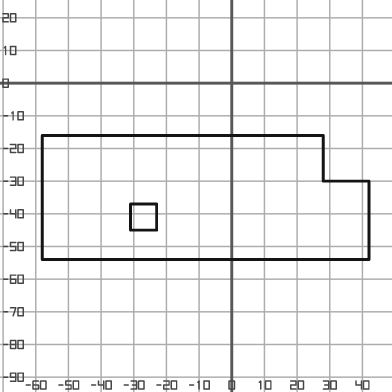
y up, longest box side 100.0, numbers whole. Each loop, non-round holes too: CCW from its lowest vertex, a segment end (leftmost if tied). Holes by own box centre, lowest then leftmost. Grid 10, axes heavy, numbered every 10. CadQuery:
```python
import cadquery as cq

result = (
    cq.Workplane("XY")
    .moveTo(-58.0, -54.0)
    .lineTo(42.0, -54.0)
    .lineTo(42.0, -30.0)
    .lineTo(28.0, -30.0)
    .lineTo(28.0, -16.0)
    .lineTo(-58.0, -16.0)
    .close()
    .moveTo(-31.0, -45.0)
    .lineTo(-23.0, -45.0)
    .lineTo(-23.0, -37.0)
    .lineTo(-31.0, -37.0)
    .close()
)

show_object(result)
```